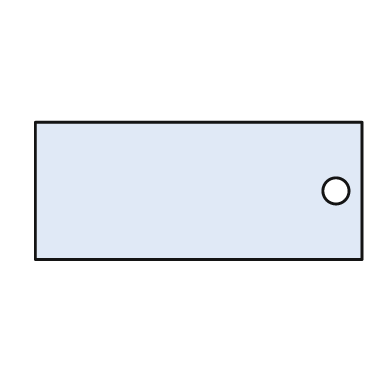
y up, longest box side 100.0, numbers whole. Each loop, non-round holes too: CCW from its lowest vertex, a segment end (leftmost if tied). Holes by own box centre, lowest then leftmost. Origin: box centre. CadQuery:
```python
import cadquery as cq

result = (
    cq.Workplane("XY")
    .moveTo(-50.0, -21.0)
    .lineTo(50.0, -21.0)
    .lineTo(50.0, 21.0)
    .lineTo(-50.0, 21.0)
    .close()
    .moveTo(42.0, 0.0)
    .circle(4.0)
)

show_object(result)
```